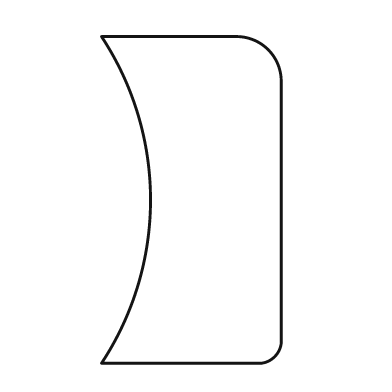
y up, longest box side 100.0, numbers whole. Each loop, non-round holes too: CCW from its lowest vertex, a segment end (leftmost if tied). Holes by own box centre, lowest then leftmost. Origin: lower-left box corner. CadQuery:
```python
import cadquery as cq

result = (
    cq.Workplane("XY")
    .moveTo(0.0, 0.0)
    .lineTo(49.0, 0.0)
    .threePointArc((53.0, 2.0), (55.0, 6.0))
    .lineTo(55.0, 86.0)
    .threePointArc((51.0, 96.0), (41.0, 100.0))
    .lineTo(0.0, 100.0)
    .threePointArc((15.0, 50.0), (0.0, 0.0))
    .close()
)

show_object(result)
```